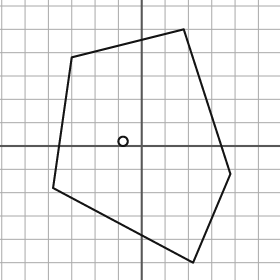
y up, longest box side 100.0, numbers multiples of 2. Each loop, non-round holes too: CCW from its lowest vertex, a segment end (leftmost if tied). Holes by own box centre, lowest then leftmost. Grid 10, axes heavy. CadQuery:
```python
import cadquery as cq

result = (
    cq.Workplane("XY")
    .moveTo(22.0, -50.0)
    .lineTo(38.0, -12.0)
    .lineTo(18.0, 50.0)
    .lineTo(-30.0, 38.0)
    .lineTo(-38.0, -18.0)
    .close()
    .moveTo(-8.0, 2.0)
    .circle(2.0)
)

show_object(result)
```